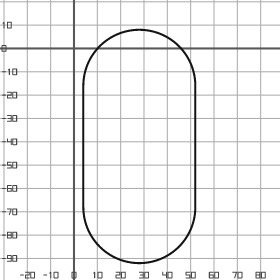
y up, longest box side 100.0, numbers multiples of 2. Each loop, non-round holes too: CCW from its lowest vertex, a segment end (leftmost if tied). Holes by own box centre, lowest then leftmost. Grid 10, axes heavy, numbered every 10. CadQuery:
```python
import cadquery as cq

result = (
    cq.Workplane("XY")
    .moveTo(4.0, -68.0)
    .threePointArc((28.0, -92.0), (52.0, -68.0))
    .lineTo(52.0, -16.0)
    .threePointArc((28.0, 8.0), (4.0, -16.0))
    .close()
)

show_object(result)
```